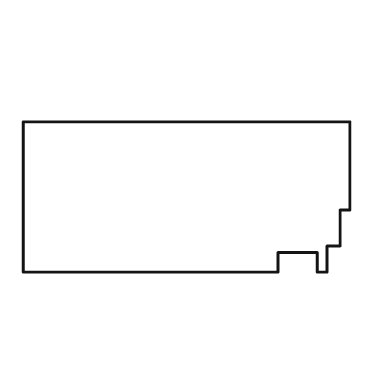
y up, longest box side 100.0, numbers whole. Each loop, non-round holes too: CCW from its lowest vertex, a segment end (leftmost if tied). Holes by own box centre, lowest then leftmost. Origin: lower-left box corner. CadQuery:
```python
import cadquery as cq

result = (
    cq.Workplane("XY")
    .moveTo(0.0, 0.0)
    .lineTo(78.0, 0.0)
    .lineTo(78.0, 6.0)
    .lineTo(90.0, 6.0)
    .lineTo(90.0, 0.0)
    .lineTo(93.0, 0.0)
    .lineTo(93.0, 8.0)
    .lineTo(97.0, 8.0)
    .lineTo(97.0, 19.0)
    .lineTo(100.0, 19.0)
    .lineTo(100.0, 46.0)
    .lineTo(0.0, 46.0)
    .close()
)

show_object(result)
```